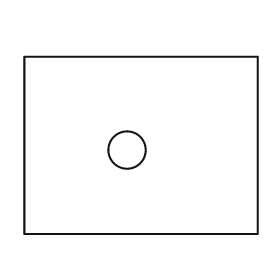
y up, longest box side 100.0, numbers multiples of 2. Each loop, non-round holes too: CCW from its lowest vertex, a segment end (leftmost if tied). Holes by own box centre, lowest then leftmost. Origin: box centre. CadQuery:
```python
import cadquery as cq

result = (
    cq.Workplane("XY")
    .moveTo(-50.0, -38.0)
    .lineTo(50.0, -38.0)
    .lineTo(50.0, 38.0)
    .lineTo(-50.0, 38.0)
    .close()
    .moveTo(-6.0, -2.0)
    .circle(8.0)
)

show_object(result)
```